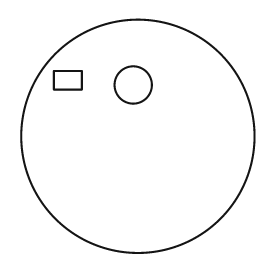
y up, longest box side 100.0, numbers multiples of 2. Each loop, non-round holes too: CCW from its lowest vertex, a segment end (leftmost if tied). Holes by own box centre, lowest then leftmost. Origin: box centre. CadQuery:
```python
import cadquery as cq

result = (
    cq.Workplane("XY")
    .moveTo(0.0, 0.0)
    .circle(50.0)
    .moveTo(-2.0, 22.0)
    .circle(8.0)
    .moveTo(-36.0, 20.0)
    .lineTo(-24.0, 20.0)
    .lineTo(-24.0, 28.0)
    .lineTo(-36.0, 28.0)
    .close()
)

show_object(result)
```